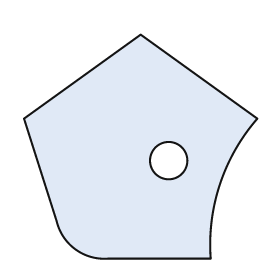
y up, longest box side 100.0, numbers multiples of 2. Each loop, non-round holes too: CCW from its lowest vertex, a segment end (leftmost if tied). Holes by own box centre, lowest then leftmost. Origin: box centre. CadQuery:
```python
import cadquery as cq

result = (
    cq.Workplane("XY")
    .moveTo(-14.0, -48.0)
    .lineTo(30.0, -48.0)
    .threePointArc((34.0, -16.0), (50.0, 12.0))
    .lineTo(0.0, 48.0)
    .lineTo(-50.0, 12.0)
    .lineTo(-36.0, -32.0)
    .threePointArc((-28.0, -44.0), (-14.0, -48.0))
    .close()
    .moveTo(12.0, -6.0)
    .circle(8.0)
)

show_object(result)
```